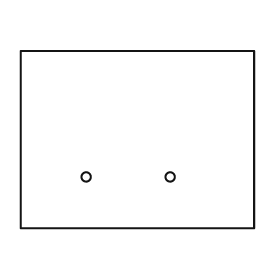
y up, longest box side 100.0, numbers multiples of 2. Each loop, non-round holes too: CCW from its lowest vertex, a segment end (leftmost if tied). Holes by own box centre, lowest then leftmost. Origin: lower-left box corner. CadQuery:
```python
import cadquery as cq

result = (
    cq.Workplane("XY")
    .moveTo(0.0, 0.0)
    .lineTo(100.0, 0.0)
    .lineTo(100.0, 76.0)
    .lineTo(0.0, 76.0)
    .close()
    .moveTo(28.0, 22.0)
    .circle(2.0)
    .moveTo(64.0, 22.0)
    .circle(2.0)
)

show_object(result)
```